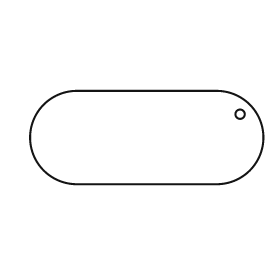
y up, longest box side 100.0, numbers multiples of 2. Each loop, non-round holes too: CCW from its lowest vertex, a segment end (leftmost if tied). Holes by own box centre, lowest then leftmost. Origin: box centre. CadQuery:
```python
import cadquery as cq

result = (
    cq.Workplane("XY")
    .moveTo(-30.0, -20.0)
    .lineTo(30.0, -20.0)
    .threePointArc((50.0, 0.0), (30.0, 20.0))
    .lineTo(-30.0, 20.0)
    .threePointArc((-50.0, 0.0), (-30.0, -20.0))
    .close()
    .moveTo(40.0, 10.0)
    .circle(2.0)
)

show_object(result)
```